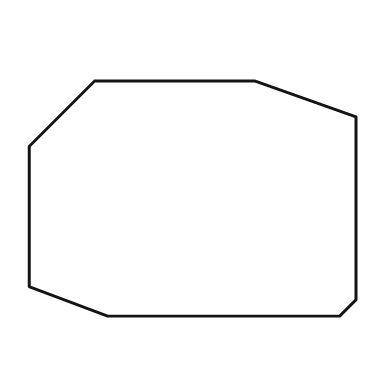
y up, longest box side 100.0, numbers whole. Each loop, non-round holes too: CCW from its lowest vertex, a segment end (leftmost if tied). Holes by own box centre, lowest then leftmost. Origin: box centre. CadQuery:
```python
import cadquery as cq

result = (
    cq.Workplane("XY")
    .moveTo(-26.0, -36.0)
    .lineTo(45.0, -36.0)
    .lineTo(50.0, -31.0)
    .lineTo(50.0, 25.0)
    .lineTo(19.0, 36.0)
    .lineTo(-30.0, 36.0)
    .lineTo(-50.0, 16.0)
    .lineTo(-50.0, -27.0)
    .close()
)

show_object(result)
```